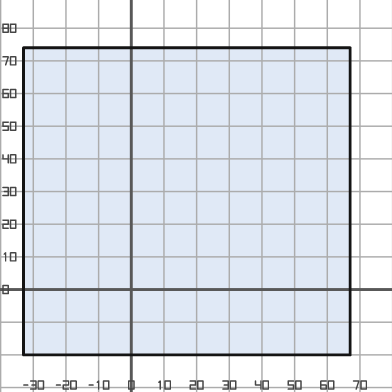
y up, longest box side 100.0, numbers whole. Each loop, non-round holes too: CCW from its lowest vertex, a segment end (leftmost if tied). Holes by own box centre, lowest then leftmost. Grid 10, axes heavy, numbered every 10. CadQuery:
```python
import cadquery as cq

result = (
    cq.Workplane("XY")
    .moveTo(-33.0, -20.0)
    .lineTo(67.0, -20.0)
    .lineTo(67.0, 74.0)
    .lineTo(-33.0, 74.0)
    .close()
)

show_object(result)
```